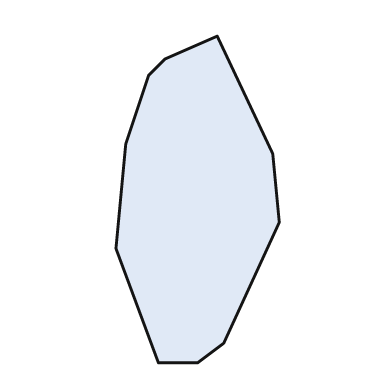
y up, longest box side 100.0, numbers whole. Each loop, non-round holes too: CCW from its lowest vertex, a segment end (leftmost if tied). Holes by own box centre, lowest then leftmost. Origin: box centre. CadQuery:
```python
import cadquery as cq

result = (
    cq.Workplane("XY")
    .moveTo(-12.0, -50.0)
    .lineTo(0.0, -50.0)
    .lineTo(8.0, -44.0)
    .lineTo(25.0, -7.0)
    .lineTo(23.0, 14.0)
    .lineTo(6.0, 50.0)
    .lineTo(-10.0, 43.0)
    .lineTo(-15.0, 38.0)
    .lineTo(-22.0, 17.0)
    .lineTo(-25.0, -15.0)
    .close()
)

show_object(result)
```